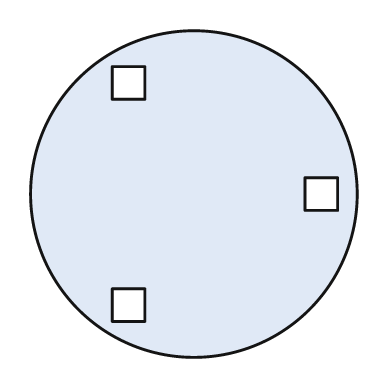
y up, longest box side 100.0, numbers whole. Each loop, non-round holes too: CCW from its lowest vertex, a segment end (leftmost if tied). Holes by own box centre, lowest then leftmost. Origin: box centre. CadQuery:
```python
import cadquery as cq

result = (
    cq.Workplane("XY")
    .moveTo(0.0, 0.0)
    .circle(50.0)
    .moveTo(-25.0, -39.0)
    .lineTo(-15.0, -39.0)
    .lineTo(-15.0, -29.0)
    .lineTo(-25.0, -29.0)
    .close()
    .moveTo(34.0, -5.0)
    .lineTo(44.0, -5.0)
    .lineTo(44.0, 5.0)
    .lineTo(34.0, 5.0)
    .close()
    .moveTo(-25.0, 29.0)
    .lineTo(-15.0, 29.0)
    .lineTo(-15.0, 39.0)
    .lineTo(-25.0, 39.0)
    .close()
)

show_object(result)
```